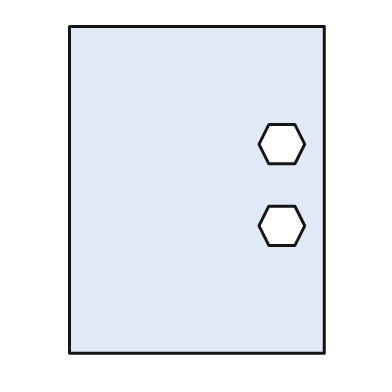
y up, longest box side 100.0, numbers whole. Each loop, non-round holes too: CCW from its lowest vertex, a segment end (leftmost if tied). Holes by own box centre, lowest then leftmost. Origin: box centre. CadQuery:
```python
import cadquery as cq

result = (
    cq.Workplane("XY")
    .moveTo(-39.0, -50.0)
    .lineTo(39.0, -50.0)
    .lineTo(39.0, 50.0)
    .lineTo(-39.0, 50.0)
    .close()
    .moveTo(22.0, -17.0)
    .lineTo(30.0, -17.0)
    .lineTo(33.0, -11.0)
    .lineTo(30.0, -5.0)
    .lineTo(22.0, -5.0)
    .lineTo(19.0, -11.0)
    .close()
    .moveTo(22.0, 8.0)
    .lineTo(30.0, 8.0)
    .lineTo(33.0, 14.0)
    .lineTo(30.0, 20.0)
    .lineTo(22.0, 20.0)
    .lineTo(19.0, 14.0)
    .close()
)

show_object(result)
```